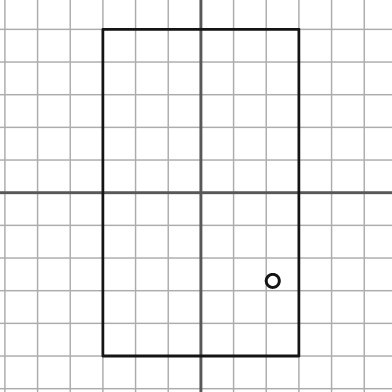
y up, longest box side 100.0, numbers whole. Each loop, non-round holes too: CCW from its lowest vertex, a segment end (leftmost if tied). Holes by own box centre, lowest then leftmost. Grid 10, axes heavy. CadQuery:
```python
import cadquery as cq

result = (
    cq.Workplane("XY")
    .moveTo(-30.0, -50.0)
    .lineTo(30.0, -50.0)
    .lineTo(30.0, 50.0)
    .lineTo(-30.0, 50.0)
    .close()
    .moveTo(22.0, -27.0)
    .circle(2.0)
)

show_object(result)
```